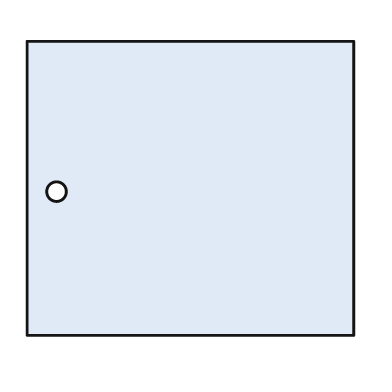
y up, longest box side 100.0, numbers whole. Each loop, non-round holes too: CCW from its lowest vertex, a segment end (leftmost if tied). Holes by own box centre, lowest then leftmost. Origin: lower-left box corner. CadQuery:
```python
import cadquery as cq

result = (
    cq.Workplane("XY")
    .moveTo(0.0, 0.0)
    .lineTo(100.0, 0.0)
    .lineTo(100.0, 90.0)
    .lineTo(0.0, 90.0)
    .close()
    .moveTo(9.0, 44.0)
    .circle(3.0)
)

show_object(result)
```